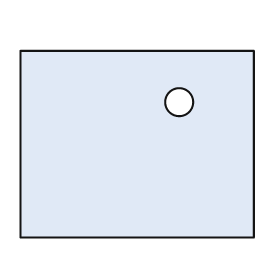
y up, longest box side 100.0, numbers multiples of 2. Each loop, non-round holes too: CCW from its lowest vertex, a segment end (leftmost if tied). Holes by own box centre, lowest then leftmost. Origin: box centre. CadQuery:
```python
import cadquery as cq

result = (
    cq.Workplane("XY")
    .moveTo(-50.0, -40.0)
    .lineTo(50.0, -40.0)
    .lineTo(50.0, 40.0)
    .lineTo(-50.0, 40.0)
    .close()
    .moveTo(18.0, 18.0)
    .circle(6.0)
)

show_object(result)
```